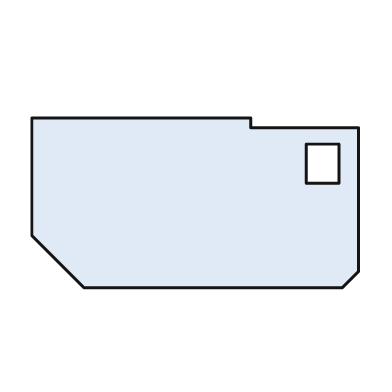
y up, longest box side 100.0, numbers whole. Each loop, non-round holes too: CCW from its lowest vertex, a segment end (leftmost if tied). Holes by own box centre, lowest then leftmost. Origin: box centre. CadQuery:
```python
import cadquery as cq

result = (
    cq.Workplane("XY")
    .moveTo(-34.0, -26.0)
    .lineTo(45.0, -26.0)
    .lineTo(50.0, -21.0)
    .lineTo(50.0, 23.0)
    .lineTo(17.0, 23.0)
    .lineTo(17.0, 26.0)
    .lineTo(-50.0, 26.0)
    .lineTo(-50.0, -10.0)
    .close()
    .moveTo(34.0, 6.0)
    .lineTo(44.0, 6.0)
    .lineTo(44.0, 18.0)
    .lineTo(34.0, 18.0)
    .close()
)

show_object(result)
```